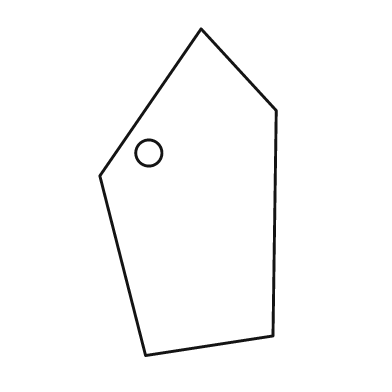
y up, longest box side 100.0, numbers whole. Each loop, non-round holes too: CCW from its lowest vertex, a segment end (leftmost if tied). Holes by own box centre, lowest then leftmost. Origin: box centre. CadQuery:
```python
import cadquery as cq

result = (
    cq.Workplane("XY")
    .moveTo(-13.0, -50.0)
    .lineTo(26.0, -44.0)
    .lineTo(27.0, 25.0)
    .lineTo(4.0, 50.0)
    .lineTo(-27.0, 5.0)
    .close()
    .moveTo(-12.0, 12.0)
    .circle(4.0)
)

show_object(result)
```